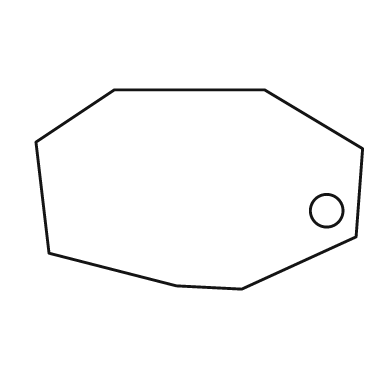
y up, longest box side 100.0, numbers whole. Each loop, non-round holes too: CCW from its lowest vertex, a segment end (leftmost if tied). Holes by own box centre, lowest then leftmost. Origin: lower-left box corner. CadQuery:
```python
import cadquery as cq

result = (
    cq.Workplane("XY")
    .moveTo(63.0, 0.0)
    .lineTo(98.0, 16.0)
    .lineTo(100.0, 43.0)
    .lineTo(70.0, 61.0)
    .lineTo(24.0, 61.0)
    .lineTo(0.0, 45.0)
    .lineTo(4.0, 11.0)
    .lineTo(43.0, 1.0)
    .close()
    .moveTo(89.0, 24.0)
    .circle(5.0)
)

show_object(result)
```